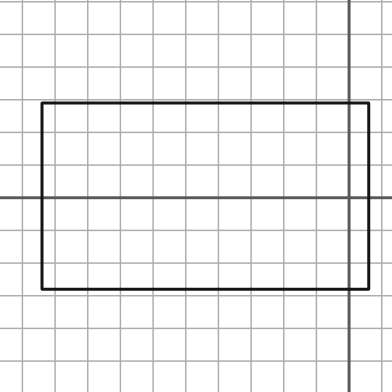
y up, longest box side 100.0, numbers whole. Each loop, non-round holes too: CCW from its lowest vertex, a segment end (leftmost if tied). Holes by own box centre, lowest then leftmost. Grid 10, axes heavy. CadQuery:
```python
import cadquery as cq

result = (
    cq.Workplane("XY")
    .moveTo(-94.0, -28.0)
    .lineTo(6.0, -28.0)
    .lineTo(6.0, 29.0)
    .lineTo(-94.0, 29.0)
    .close()
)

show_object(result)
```